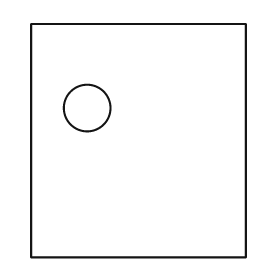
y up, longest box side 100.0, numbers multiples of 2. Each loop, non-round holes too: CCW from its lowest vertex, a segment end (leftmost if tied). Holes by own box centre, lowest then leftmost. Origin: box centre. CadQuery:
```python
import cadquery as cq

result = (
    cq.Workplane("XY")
    .moveTo(-46.0, -50.0)
    .lineTo(46.0, -50.0)
    .lineTo(46.0, 50.0)
    .lineTo(-46.0, 50.0)
    .close()
    .moveTo(-22.0, 14.0)
    .circle(10.0)
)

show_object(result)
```